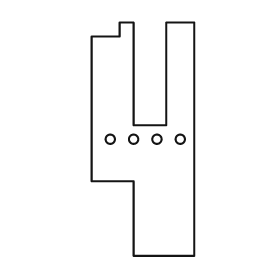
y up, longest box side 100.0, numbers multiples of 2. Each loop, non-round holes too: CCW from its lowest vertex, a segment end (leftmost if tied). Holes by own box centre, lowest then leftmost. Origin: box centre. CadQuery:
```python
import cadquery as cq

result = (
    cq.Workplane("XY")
    .moveTo(-4.0, -50.0)
    .lineTo(22.0, -50.0)
    .lineTo(22.0, 50.0)
    .lineTo(10.0, 50.0)
    .lineTo(10.0, 6.0)
    .lineTo(-4.0, 6.0)
    .lineTo(-4.0, 50.0)
    .lineTo(-10.0, 50.0)
    .lineTo(-10.0, 44.0)
    .lineTo(-22.0, 44.0)
    .lineTo(-22.0, -18.0)
    .lineTo(-4.0, -18.0)
    .close()
    .moveTo(-14.0, 0.0)
    .circle(2.0)
    .moveTo(-4.0, 0.0)
    .circle(2.0)
    .moveTo(6.0, 0.0)
    .circle(2.0)
    .moveTo(16.0, 0.0)
    .circle(2.0)
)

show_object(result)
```